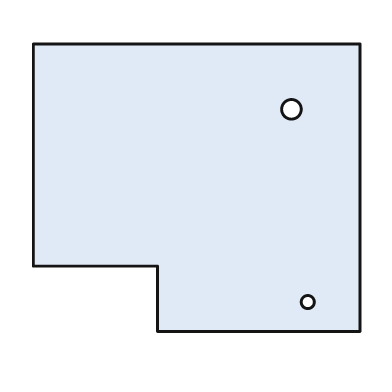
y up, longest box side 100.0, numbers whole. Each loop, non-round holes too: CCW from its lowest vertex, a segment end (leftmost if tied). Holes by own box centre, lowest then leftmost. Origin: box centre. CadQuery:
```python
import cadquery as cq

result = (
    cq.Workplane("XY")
    .moveTo(-12.0, -44.0)
    .lineTo(50.0, -44.0)
    .lineTo(50.0, 44.0)
    .lineTo(-50.0, 44.0)
    .lineTo(-50.0, -24.0)
    .lineTo(-12.0, -24.0)
    .close()
    .moveTo(34.0, -35.0)
    .circle(2.0)
    .moveTo(29.0, 24.0)
    .circle(3.0)
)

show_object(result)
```